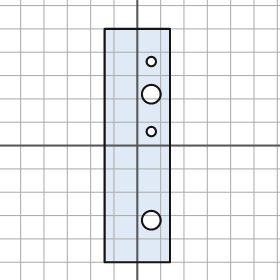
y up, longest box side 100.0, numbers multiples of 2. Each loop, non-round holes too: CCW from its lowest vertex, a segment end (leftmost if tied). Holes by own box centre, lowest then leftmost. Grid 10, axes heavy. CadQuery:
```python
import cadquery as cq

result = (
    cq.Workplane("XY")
    .moveTo(-14.0, -50.0)
    .lineTo(14.0, -50.0)
    .lineTo(14.0, 50.0)
    .lineTo(-14.0, 50.0)
    .close()
    .moveTo(6.0, -32.0)
    .circle(4.0)
    .moveTo(6.0, 6.0)
    .circle(2.0)
    .moveTo(6.0, 22.0)
    .circle(4.0)
    .moveTo(6.0, 36.0)
    .circle(2.0)
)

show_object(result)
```